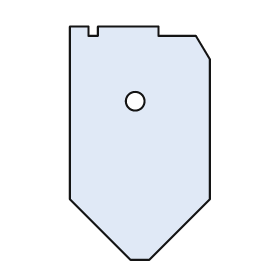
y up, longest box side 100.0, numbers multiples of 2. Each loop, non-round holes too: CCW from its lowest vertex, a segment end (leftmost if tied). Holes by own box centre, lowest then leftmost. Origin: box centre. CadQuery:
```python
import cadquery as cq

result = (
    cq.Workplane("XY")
    .moveTo(-4.0, -50.0)
    .lineTo(4.0, -50.0)
    .lineTo(30.0, -24.0)
    .lineTo(30.0, 36.0)
    .lineTo(24.0, 46.0)
    .lineTo(8.0, 46.0)
    .lineTo(8.0, 50.0)
    .lineTo(-18.0, 50.0)
    .lineTo(-18.0, 46.0)
    .lineTo(-22.0, 46.0)
    .lineTo(-22.0, 50.0)
    .lineTo(-30.0, 50.0)
    .lineTo(-30.0, -24.0)
    .close()
    .moveTo(-2.0, 18.0)
    .circle(4.0)
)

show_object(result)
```